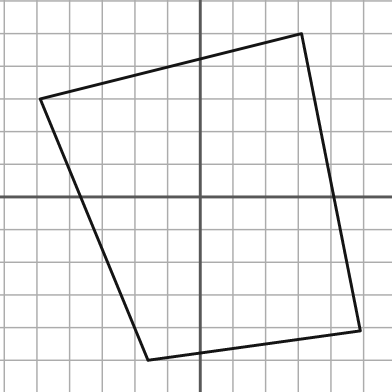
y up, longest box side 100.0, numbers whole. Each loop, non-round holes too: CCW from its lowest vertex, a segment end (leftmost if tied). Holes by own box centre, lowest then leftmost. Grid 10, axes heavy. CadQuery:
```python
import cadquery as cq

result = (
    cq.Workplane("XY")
    .moveTo(-16.0, -50.0)
    .lineTo(49.0, -41.0)
    .lineTo(31.0, 50.0)
    .lineTo(-49.0, 30.0)
    .close()
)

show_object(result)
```